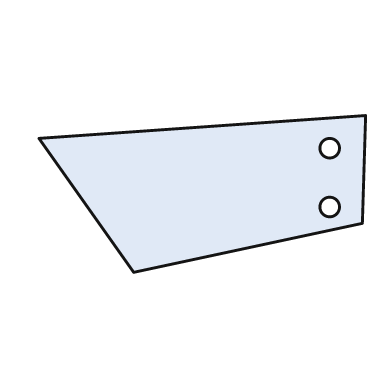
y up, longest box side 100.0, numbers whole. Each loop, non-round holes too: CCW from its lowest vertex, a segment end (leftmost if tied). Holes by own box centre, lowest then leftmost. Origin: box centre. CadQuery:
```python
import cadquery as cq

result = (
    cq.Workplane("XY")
    .moveTo(-21.0, -24.0)
    .lineTo(49.0, -9.0)
    .lineTo(50.0, 24.0)
    .lineTo(-50.0, 17.0)
    .close()
    .moveTo(39.0, -4.0)
    .circle(3.0)
    .moveTo(39.0, 14.0)
    .circle(3.0)
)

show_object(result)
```